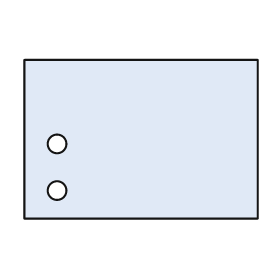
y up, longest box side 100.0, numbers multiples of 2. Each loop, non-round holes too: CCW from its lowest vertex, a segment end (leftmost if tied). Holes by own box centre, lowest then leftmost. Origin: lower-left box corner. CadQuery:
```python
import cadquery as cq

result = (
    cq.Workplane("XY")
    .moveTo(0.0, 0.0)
    .lineTo(100.0, 0.0)
    .lineTo(100.0, 68.0)
    .lineTo(0.0, 68.0)
    .close()
    .moveTo(14.0, 12.0)
    .circle(4.0)
    .moveTo(14.0, 32.0)
    .circle(4.0)
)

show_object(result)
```